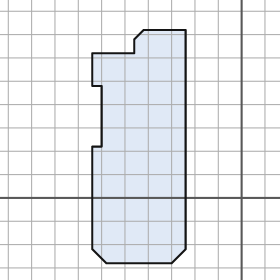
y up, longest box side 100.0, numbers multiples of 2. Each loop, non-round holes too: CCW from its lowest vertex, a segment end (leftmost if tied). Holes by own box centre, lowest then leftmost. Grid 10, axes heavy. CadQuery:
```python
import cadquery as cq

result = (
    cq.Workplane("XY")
    .moveTo(-58.0, -28.0)
    .lineTo(-30.0, -28.0)
    .lineTo(-24.0, -22.0)
    .lineTo(-24.0, 72.0)
    .lineTo(-42.0, 72.0)
    .lineTo(-46.0, 68.0)
    .lineTo(-46.0, 62.0)
    .lineTo(-64.0, 62.0)
    .lineTo(-64.0, 48.0)
    .lineTo(-60.0, 48.0)
    .lineTo(-60.0, 22.0)
    .lineTo(-64.0, 22.0)
    .lineTo(-64.0, -22.0)
    .close()
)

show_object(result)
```